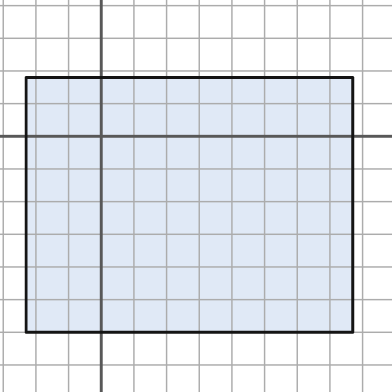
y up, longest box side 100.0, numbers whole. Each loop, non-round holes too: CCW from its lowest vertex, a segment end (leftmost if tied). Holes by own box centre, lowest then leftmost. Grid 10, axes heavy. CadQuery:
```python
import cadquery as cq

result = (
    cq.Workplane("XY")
    .moveTo(-23.0, -60.0)
    .lineTo(77.0, -60.0)
    .lineTo(77.0, 18.0)
    .lineTo(-23.0, 18.0)
    .close()
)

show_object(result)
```